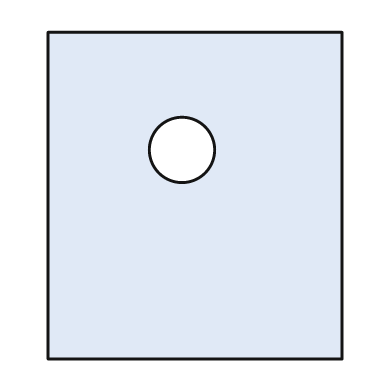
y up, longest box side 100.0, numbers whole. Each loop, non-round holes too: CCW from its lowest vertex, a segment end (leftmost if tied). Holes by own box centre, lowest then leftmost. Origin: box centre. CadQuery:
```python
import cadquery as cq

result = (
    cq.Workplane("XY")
    .moveTo(-45.0, -50.0)
    .lineTo(45.0, -50.0)
    .lineTo(45.0, 50.0)
    .lineTo(-45.0, 50.0)
    .close()
    .moveTo(-4.0, 14.0)
    .circle(10.0)
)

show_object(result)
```